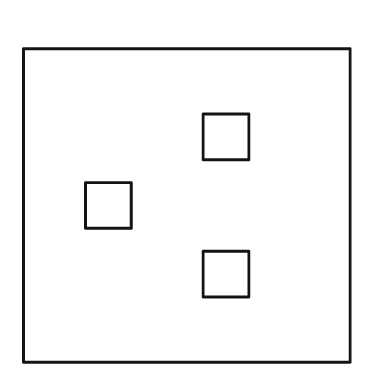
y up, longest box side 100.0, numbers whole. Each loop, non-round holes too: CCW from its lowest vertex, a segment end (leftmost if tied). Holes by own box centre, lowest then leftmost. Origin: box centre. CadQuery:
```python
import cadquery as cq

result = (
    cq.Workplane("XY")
    .moveTo(-50.0, -48.0)
    .lineTo(50.0, -48.0)
    .lineTo(50.0, 48.0)
    .lineTo(-50.0, 48.0)
    .close()
    .moveTo(5.0, -28.0)
    .lineTo(19.0, -28.0)
    .lineTo(19.0, -14.0)
    .lineTo(5.0, -14.0)
    .close()
    .moveTo(-31.0, -7.0)
    .lineTo(-17.0, -7.0)
    .lineTo(-17.0, 7.0)
    .lineTo(-31.0, 7.0)
    .close()
    .moveTo(5.0, 14.0)
    .lineTo(19.0, 14.0)
    .lineTo(19.0, 28.0)
    .lineTo(5.0, 28.0)
    .close()
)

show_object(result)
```